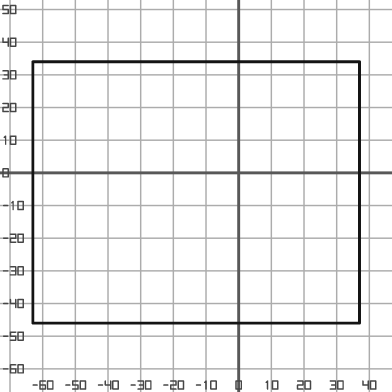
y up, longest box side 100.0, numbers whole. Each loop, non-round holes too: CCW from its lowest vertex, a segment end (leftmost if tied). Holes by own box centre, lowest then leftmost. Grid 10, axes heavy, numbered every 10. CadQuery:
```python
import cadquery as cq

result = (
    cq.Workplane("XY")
    .moveTo(-63.0, -46.0)
    .lineTo(37.0, -46.0)
    .lineTo(37.0, 34.0)
    .lineTo(-63.0, 34.0)
    .close()
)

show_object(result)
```